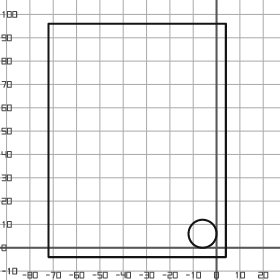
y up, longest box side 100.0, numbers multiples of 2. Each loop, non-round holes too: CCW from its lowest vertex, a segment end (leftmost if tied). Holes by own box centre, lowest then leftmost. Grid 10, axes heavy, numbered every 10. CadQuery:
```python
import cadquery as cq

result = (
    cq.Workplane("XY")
    .moveTo(-72.0, -4.0)
    .lineTo(4.0, -4.0)
    .lineTo(4.0, 96.0)
    .lineTo(-72.0, 96.0)
    .close()
    .moveTo(-6.0, 6.0)
    .circle(6.0)
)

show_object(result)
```